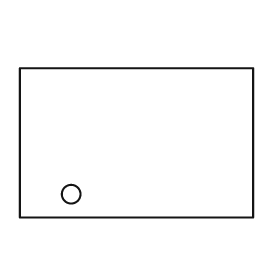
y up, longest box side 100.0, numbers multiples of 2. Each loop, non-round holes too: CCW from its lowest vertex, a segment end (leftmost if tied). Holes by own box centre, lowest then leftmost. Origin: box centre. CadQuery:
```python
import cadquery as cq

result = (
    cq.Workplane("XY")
    .moveTo(-50.0, -32.0)
    .lineTo(50.0, -32.0)
    .lineTo(50.0, 32.0)
    .lineTo(-50.0, 32.0)
    .close()
    .moveTo(-28.0, -22.0)
    .circle(4.0)
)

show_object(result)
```